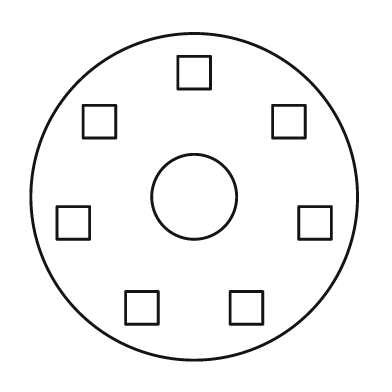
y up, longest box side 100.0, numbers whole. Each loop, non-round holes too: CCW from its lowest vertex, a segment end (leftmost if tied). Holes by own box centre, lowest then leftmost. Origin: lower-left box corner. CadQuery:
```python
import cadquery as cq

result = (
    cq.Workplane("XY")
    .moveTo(50.0, 50.0)
    .circle(50.0)
    .moveTo(29.0, 11.0)
    .lineTo(39.0, 11.0)
    .lineTo(39.0, 21.0)
    .lineTo(29.0, 21.0)
    .close()
    .moveTo(61.0, 11.0)
    .lineTo(71.0, 11.0)
    .lineTo(71.0, 21.0)
    .lineTo(61.0, 21.0)
    .close()
    .moveTo(8.0, 37.0)
    .lineTo(18.0, 37.0)
    .lineTo(18.0, 47.0)
    .lineTo(8.0, 47.0)
    .close()
    .moveTo(82.0, 37.0)
    .lineTo(92.0, 37.0)
    .lineTo(92.0, 47.0)
    .lineTo(82.0, 47.0)
    .close()
    .moveTo(50.0, 50.0)
    .circle(13.0)
    .moveTo(16.0, 68.0)
    .lineTo(26.0, 68.0)
    .lineTo(26.0, 78.0)
    .lineTo(16.0, 78.0)
    .close()
    .moveTo(74.0, 68.0)
    .lineTo(84.0, 68.0)
    .lineTo(84.0, 78.0)
    .lineTo(74.0, 78.0)
    .close()
    .moveTo(45.0, 83.0)
    .lineTo(55.0, 83.0)
    .lineTo(55.0, 93.0)
    .lineTo(45.0, 93.0)
    .close()
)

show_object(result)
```